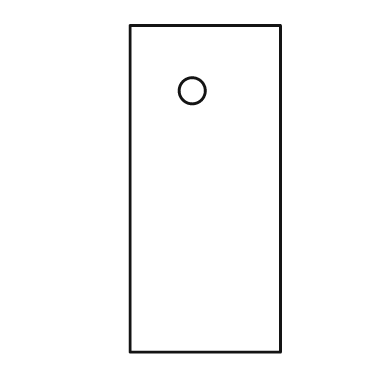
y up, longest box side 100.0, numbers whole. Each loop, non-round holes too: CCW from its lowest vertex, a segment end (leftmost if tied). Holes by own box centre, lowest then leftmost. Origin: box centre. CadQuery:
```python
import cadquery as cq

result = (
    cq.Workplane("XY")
    .moveTo(-23.0, -50.0)
    .lineTo(23.0, -50.0)
    .lineTo(23.0, 50.0)
    .lineTo(-23.0, 50.0)
    .close()
    .moveTo(-4.0, 30.0)
    .circle(4.0)
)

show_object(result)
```